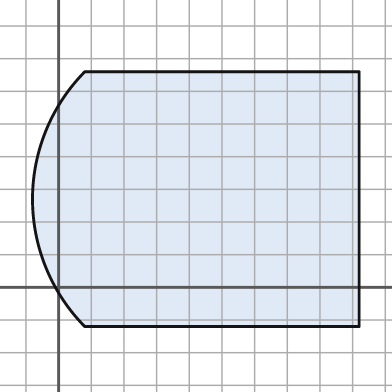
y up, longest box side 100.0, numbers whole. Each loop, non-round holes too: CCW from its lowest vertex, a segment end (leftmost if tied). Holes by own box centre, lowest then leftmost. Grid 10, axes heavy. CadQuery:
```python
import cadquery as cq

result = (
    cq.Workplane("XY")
    .moveTo(8.0, -12.0)
    .lineTo(92.0, -12.0)
    .lineTo(92.0, 66.0)
    .lineTo(8.0, 66.0)
    .threePointArc((-8.0, 27.0), (8.0, -12.0))
    .close()
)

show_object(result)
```